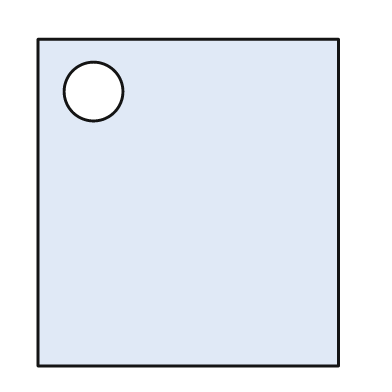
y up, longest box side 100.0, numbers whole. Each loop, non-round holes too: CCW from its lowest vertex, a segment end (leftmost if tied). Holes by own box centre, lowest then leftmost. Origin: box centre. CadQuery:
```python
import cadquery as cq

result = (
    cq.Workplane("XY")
    .moveTo(-46.0, -50.0)
    .lineTo(46.0, -50.0)
    .lineTo(46.0, 50.0)
    .lineTo(-46.0, 50.0)
    .close()
    .moveTo(-29.0, 34.0)
    .circle(9.0)
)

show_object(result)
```